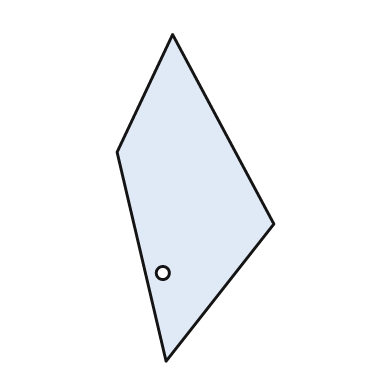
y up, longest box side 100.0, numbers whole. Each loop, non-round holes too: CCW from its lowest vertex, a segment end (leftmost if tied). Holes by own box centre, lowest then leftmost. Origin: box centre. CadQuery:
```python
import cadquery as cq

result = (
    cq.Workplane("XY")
    .moveTo(-9.0, -50.0)
    .lineTo(24.0, -8.0)
    .lineTo(-7.0, 50.0)
    .lineTo(-24.0, 14.0)
    .close()
    .moveTo(-10.0, -23.0)
    .circle(2.0)
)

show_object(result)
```